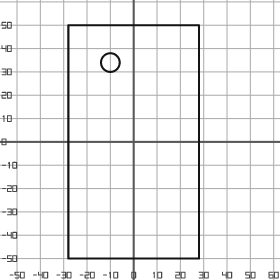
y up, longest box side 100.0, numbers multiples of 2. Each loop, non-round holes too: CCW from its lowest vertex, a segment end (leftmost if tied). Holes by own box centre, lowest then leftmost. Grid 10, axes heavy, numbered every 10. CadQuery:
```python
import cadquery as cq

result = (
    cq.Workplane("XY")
    .moveTo(-28.0, -50.0)
    .lineTo(28.0, -50.0)
    .lineTo(28.0, 50.0)
    .lineTo(-28.0, 50.0)
    .close()
    .moveTo(-10.0, 34.0)
    .circle(4.0)
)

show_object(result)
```